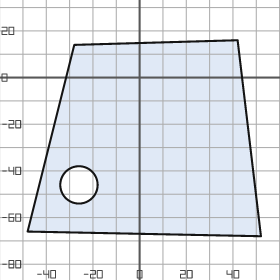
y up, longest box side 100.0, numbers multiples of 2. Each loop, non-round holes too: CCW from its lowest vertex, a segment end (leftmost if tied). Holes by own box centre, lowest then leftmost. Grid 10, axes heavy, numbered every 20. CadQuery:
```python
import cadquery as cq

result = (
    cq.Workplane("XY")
    .moveTo(52.0, -68.0)
    .lineTo(42.0, 16.0)
    .lineTo(-28.0, 14.0)
    .lineTo(-48.0, -66.0)
    .close()
    .moveTo(-26.0, -46.0)
    .circle(8.0)
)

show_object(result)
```